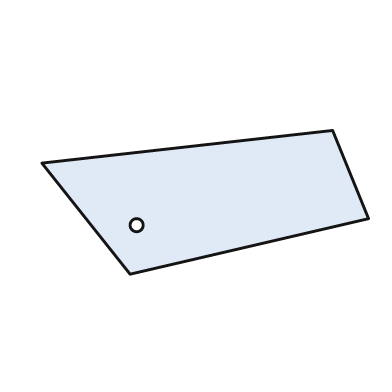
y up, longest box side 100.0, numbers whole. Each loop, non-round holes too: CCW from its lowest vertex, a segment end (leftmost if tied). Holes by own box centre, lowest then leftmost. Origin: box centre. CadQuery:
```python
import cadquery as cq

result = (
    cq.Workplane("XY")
    .moveTo(-23.0, -22.0)
    .lineTo(50.0, -5.0)
    .lineTo(39.0, 22.0)
    .lineTo(-50.0, 12.0)
    .close()
    .moveTo(-21.0, -7.0)
    .circle(2.0)
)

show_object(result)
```